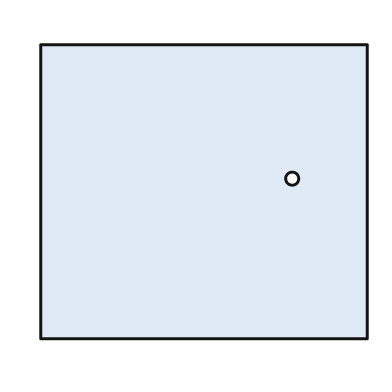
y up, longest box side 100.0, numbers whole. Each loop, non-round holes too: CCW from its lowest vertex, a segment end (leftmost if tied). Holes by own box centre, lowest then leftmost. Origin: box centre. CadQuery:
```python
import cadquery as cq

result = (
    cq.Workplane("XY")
    .moveTo(-50.0, -45.0)
    .lineTo(50.0, -45.0)
    .lineTo(50.0, 45.0)
    .lineTo(-50.0, 45.0)
    .close()
    .moveTo(27.0, 4.0)
    .circle(2.0)
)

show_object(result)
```